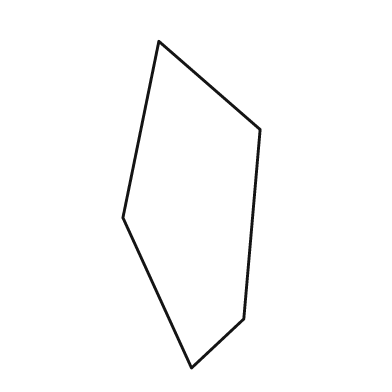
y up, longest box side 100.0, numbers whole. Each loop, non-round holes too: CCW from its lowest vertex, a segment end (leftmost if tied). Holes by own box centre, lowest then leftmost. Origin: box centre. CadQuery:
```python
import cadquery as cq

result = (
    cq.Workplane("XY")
    .moveTo(0.0, -50.0)
    .lineTo(16.0, -35.0)
    .lineTo(21.0, 23.0)
    .lineTo(-10.0, 50.0)
    .lineTo(-21.0, -4.0)
    .close()
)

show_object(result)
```